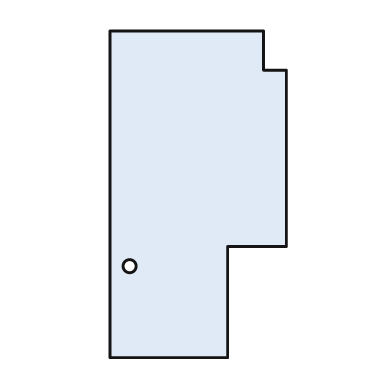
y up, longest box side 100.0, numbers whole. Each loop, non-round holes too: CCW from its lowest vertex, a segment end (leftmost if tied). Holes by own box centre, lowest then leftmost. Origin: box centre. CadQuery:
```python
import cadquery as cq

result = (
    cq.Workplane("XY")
    .moveTo(-27.0, -50.0)
    .lineTo(9.0, -50.0)
    .lineTo(9.0, -16.0)
    .lineTo(27.0, -16.0)
    .lineTo(27.0, 38.0)
    .lineTo(20.0, 38.0)
    .lineTo(20.0, 50.0)
    .lineTo(-27.0, 50.0)
    .close()
    .moveTo(-21.0, -22.0)
    .circle(2.0)
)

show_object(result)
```